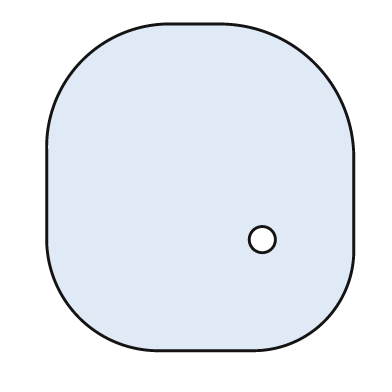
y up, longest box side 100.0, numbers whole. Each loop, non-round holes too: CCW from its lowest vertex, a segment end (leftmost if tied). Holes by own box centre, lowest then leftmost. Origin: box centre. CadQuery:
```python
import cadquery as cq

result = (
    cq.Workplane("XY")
    .moveTo(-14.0, -50.0)
    .lineTo(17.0, -50.0)
    .threePointArc((38.0, -41.0), (47.0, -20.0))
    .lineTo(47.0, 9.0)
    .threePointArc((35.0, 38.0), (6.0, 50.0))
    .lineTo(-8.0, 50.0)
    .threePointArc((-36.0, 39.0), (-47.0, 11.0))
    .lineTo(-47.0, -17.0)
    .threePointArc((-37.0, -40.0), (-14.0, -50.0))
    .close()
    .moveTo(19.0, -16.0)
    .circle(4.0)
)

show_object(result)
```